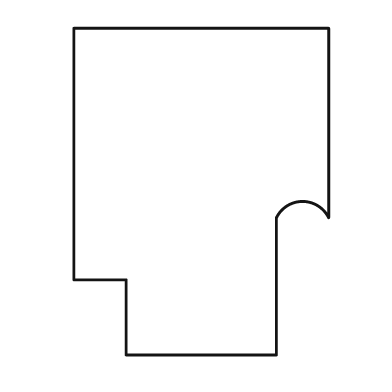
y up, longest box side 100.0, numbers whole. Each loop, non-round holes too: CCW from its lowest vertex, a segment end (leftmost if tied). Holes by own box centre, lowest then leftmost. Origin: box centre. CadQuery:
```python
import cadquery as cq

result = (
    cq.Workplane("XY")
    .moveTo(-23.0, -50.0)
    .lineTo(23.0, -50.0)
    .lineTo(23.0, -8.0)
    .threePointArc((31.0, -3.0), (39.0, -8.0))
    .lineTo(39.0, 50.0)
    .lineTo(-39.0, 50.0)
    .lineTo(-39.0, -27.0)
    .lineTo(-23.0, -27.0)
    .close()
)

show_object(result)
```